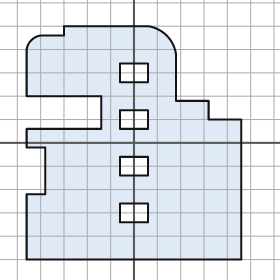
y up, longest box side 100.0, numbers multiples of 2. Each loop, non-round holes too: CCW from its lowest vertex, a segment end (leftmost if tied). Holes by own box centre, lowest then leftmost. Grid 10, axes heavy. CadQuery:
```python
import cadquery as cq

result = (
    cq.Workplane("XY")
    .moveTo(-46.0, -50.0)
    .lineTo(46.0, -50.0)
    .lineTo(46.0, 10.0)
    .lineTo(32.0, 10.0)
    .lineTo(32.0, 18.0)
    .lineTo(18.0, 18.0)
    .lineTo(18.0, 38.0)
    .threePointArc((14.0, 46.0), (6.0, 50.0))
    .lineTo(-30.0, 50.0)
    .lineTo(-30.0, 46.0)
    .lineTo(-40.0, 46.0)
    .threePointArc((-44.0, 44.0), (-46.0, 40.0))
    .lineTo(-46.0, 20.0)
    .lineTo(-14.0, 20.0)
    .lineTo(-14.0, 6.0)
    .lineTo(-46.0, 6.0)
    .lineTo(-46.0, -2.0)
    .lineTo(-38.0, -2.0)
    .lineTo(-38.0, -22.0)
    .lineTo(-46.0, -22.0)
    .close()
    .moveTo(-6.0, -34.0)
    .lineTo(6.0, -34.0)
    .lineTo(6.0, -26.0)
    .lineTo(-6.0, -26.0)
    .close()
    .moveTo(-6.0, -14.0)
    .lineTo(6.0, -14.0)
    .lineTo(6.0, -6.0)
    .lineTo(-6.0, -6.0)
    .close()
    .moveTo(-6.0, 6.0)
    .lineTo(6.0, 6.0)
    .lineTo(6.0, 14.0)
    .lineTo(-6.0, 14.0)
    .close()
    .moveTo(-6.0, 26.0)
    .lineTo(6.0, 26.0)
    .lineTo(6.0, 34.0)
    .lineTo(-6.0, 34.0)
    .close()
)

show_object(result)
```